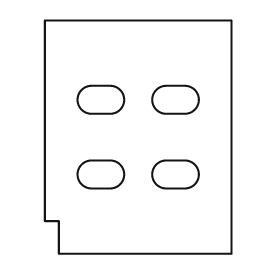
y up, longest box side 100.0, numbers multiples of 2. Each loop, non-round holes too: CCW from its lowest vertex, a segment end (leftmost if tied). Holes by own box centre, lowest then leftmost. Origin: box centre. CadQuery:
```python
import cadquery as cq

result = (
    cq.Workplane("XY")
    .moveTo(-34.0, -50.0)
    .lineTo(40.0, -50.0)
    .lineTo(40.0, 50.0)
    .lineTo(-40.0, 50.0)
    .lineTo(-40.0, -36.0)
    .lineTo(-34.0, -36.0)
    .close()
    .moveTo(-20.0, -22.0)
    .lineTo(-12.0, -22.0)
    .threePointArc((-6.0, -16.0), (-12.0, -10.0))
    .lineTo(-20.0, -10.0)
    .threePointArc((-26.0, -16.0), (-20.0, -22.0))
    .close()
    .moveTo(12.0, -22.0)
    .lineTo(20.0, -22.0)
    .threePointArc((26.0, -16.0), (20.0, -10.0))
    .lineTo(12.0, -10.0)
    .threePointArc((6.0, -16.0), (12.0, -22.0))
    .close()
    .moveTo(-20.0, 10.0)
    .lineTo(-12.0, 10.0)
    .threePointArc((-6.0, 16.0), (-12.0, 22.0))
    .lineTo(-20.0, 22.0)
    .threePointArc((-26.0, 16.0), (-20.0, 10.0))
    .close()
    .moveTo(12.0, 10.0)
    .lineTo(20.0, 10.0)
    .threePointArc((26.0, 16.0), (20.0, 22.0))
    .lineTo(12.0, 22.0)
    .threePointArc((6.0, 16.0), (12.0, 10.0))
    .close()
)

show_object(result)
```